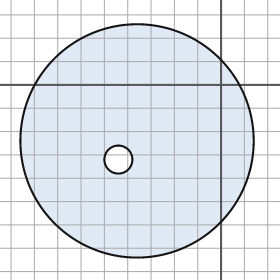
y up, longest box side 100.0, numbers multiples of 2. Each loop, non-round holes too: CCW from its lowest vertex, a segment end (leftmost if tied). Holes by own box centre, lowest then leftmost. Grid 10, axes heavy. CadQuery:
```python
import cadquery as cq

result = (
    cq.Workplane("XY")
    .moveTo(-36.0, -24.0)
    .circle(50.0)
    .moveTo(-44.0, -32.0)
    .circle(6.0)
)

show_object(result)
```